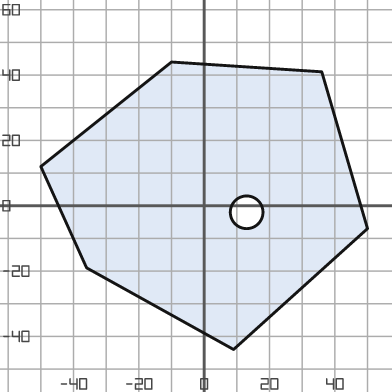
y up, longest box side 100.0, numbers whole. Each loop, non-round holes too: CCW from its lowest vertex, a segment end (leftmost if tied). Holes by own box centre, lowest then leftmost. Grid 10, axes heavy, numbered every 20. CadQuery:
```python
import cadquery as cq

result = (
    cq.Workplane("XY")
    .moveTo(9.0, -44.0)
    .lineTo(50.0, -7.0)
    .lineTo(36.0, 41.0)
    .lineTo(-10.0, 44.0)
    .lineTo(-50.0, 12.0)
    .lineTo(-36.0, -19.0)
    .close()
    .moveTo(13.0, -2.0)
    .circle(5.0)
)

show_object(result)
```